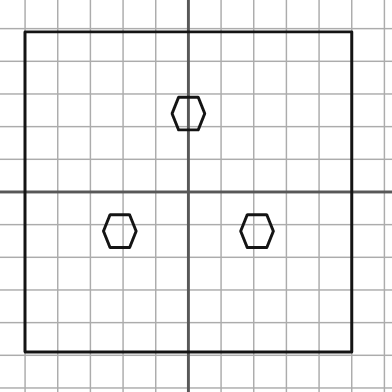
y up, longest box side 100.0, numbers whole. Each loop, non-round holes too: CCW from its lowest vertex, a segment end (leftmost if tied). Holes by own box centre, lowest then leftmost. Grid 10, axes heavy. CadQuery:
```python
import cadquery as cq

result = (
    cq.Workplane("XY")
    .moveTo(-50.0, -49.0)
    .lineTo(50.0, -49.0)
    .lineTo(50.0, 49.0)
    .lineTo(-50.0, 49.0)
    .close()
    .moveTo(-24.0, -17.0)
    .lineTo(-18.0, -17.0)
    .lineTo(-16.0, -12.0)
    .lineTo(-18.0, -7.0)
    .lineTo(-24.0, -7.0)
    .lineTo(-26.0, -12.0)
    .close()
    .moveTo(18.0, -17.0)
    .lineTo(24.0, -17.0)
    .lineTo(26.0, -12.0)
    .lineTo(24.0, -7.0)
    .lineTo(18.0, -7.0)
    .lineTo(16.0, -12.0)
    .close()
    .moveTo(-3.0, 19.0)
    .lineTo(3.0, 19.0)
    .lineTo(5.0, 24.0)
    .lineTo(3.0, 29.0)
    .lineTo(-3.0, 29.0)
    .lineTo(-5.0, 24.0)
    .close()
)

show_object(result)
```